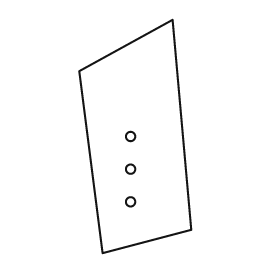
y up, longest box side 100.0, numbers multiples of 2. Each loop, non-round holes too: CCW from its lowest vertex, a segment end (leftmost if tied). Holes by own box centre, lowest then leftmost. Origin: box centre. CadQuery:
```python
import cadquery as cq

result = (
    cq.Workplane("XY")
    .moveTo(-14.0, -50.0)
    .lineTo(24.0, -40.0)
    .lineTo(16.0, 50.0)
    .lineTo(-24.0, 28.0)
    .close()
    .moveTo(-2.0, -28.0)
    .circle(2.0)
    .moveTo(-2.0, -14.0)
    .circle(2.0)
    .moveTo(-2.0, 0.0)
    .circle(2.0)
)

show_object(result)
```